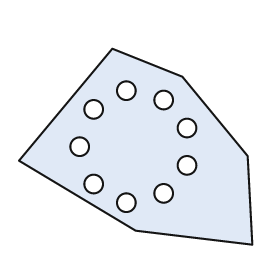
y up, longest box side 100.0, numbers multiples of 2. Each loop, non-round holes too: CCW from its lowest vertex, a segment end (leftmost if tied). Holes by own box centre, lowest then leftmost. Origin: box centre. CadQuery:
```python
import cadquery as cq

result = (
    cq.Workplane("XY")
    .moveTo(50.0, -42.0)
    .lineTo(48.0, -4.0)
    .lineTo(20.0, 30.0)
    .lineTo(-10.0, 42.0)
    .lineTo(-50.0, -6.0)
    .lineTo(0.0, -36.0)
    .close()
    .moveTo(-4.0, -24.0)
    .circle(4.0)
    .moveTo(12.0, -20.0)
    .circle(4.0)
    .moveTo(-18.0, -16.0)
    .circle(4.0)
    .moveTo(22.0, -8.0)
    .circle(4.0)
    .moveTo(-24.0, 0.0)
    .circle(4.0)
    .moveTo(22.0, 8.0)
    .circle(4.0)
    .moveTo(-18.0, 16.0)
    .circle(4.0)
    .moveTo(12.0, 20.0)
    .circle(4.0)
    .moveTo(-4.0, 24.0)
    .circle(4.0)
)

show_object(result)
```